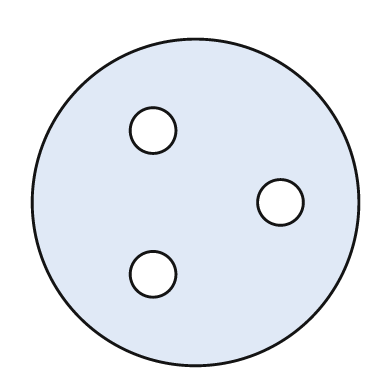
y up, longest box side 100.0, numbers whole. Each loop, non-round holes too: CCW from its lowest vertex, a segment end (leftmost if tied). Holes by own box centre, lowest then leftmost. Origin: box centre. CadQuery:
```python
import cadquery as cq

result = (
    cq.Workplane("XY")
    .moveTo(0.0, 0.0)
    .circle(50.0)
    .moveTo(-13.0, -22.0)
    .circle(7.0)
    .moveTo(26.0, 0.0)
    .circle(7.0)
    .moveTo(-13.0, 22.0)
    .circle(7.0)
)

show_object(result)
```